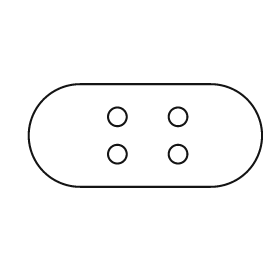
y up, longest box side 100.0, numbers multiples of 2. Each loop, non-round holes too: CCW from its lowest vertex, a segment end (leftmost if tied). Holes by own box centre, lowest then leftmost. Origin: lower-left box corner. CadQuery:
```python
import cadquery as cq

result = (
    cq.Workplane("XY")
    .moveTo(22.0, 0.0)
    .lineTo(78.0, 0.0)
    .threePointArc((100.0, 22.0), (78.0, 44.0))
    .lineTo(22.0, 44.0)
    .threePointArc((0.0, 22.0), (22.0, 0.0))
    .close()
    .moveTo(38.0, 14.0)
    .circle(4.0)
    .moveTo(64.0, 14.0)
    .circle(4.0)
    .moveTo(38.0, 30.0)
    .circle(4.0)
    .moveTo(64.0, 30.0)
    .circle(4.0)
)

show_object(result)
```